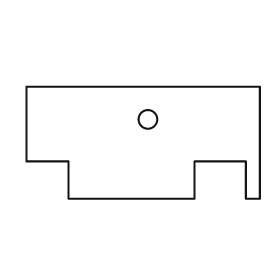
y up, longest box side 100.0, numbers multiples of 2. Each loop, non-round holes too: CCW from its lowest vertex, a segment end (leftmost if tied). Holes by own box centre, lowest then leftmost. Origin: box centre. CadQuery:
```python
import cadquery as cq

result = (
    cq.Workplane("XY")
    .moveTo(-32.0, -24.0)
    .lineTo(22.0, -24.0)
    .lineTo(22.0, -8.0)
    .lineTo(44.0, -8.0)
    .lineTo(44.0, -24.0)
    .lineTo(50.0, -24.0)
    .lineTo(50.0, 24.0)
    .lineTo(-50.0, 24.0)
    .lineTo(-50.0, -8.0)
    .lineTo(-32.0, -8.0)
    .close()
    .moveTo(2.0, 10.0)
    .circle(4.0)
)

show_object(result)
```